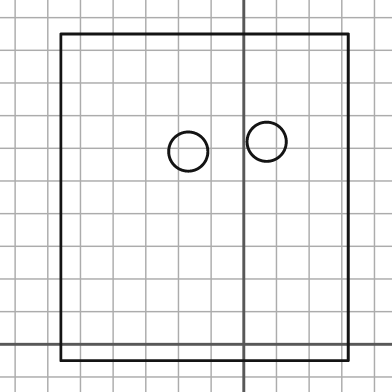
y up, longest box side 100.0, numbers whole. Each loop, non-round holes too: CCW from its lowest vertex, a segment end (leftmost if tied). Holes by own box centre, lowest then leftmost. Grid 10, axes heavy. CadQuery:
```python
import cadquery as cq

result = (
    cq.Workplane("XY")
    .moveTo(-56.0, -5.0)
    .lineTo(32.0, -5.0)
    .lineTo(32.0, 95.0)
    .lineTo(-56.0, 95.0)
    .close()
    .moveTo(-17.0, 59.0)
    .circle(6.0)
    .moveTo(7.0, 62.0)
    .circle(6.0)
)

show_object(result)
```